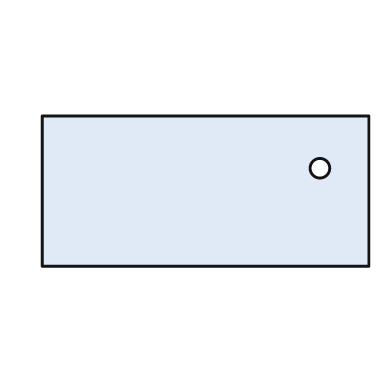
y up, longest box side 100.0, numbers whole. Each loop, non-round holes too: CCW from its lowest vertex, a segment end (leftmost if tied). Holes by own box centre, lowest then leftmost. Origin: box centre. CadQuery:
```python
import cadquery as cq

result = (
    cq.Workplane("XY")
    .moveTo(-50.0, -23.0)
    .lineTo(50.0, -23.0)
    .lineTo(50.0, 23.0)
    .lineTo(-50.0, 23.0)
    .close()
    .moveTo(35.0, 7.0)
    .circle(3.0)
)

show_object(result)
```